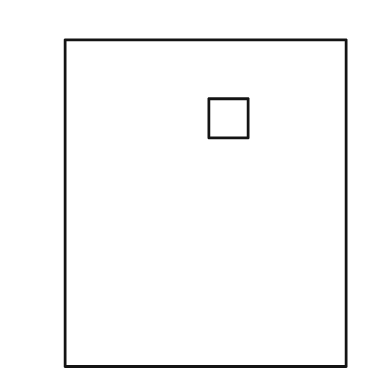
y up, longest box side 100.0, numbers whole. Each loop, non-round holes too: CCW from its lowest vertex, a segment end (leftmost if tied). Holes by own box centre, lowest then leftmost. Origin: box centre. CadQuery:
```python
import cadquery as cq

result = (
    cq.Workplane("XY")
    .moveTo(-43.0, -50.0)
    .lineTo(43.0, -50.0)
    .lineTo(43.0, 50.0)
    .lineTo(-43.0, 50.0)
    .close()
    .moveTo(1.0, 20.0)
    .lineTo(13.0, 20.0)
    .lineTo(13.0, 32.0)
    .lineTo(1.0, 32.0)
    .close()
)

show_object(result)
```